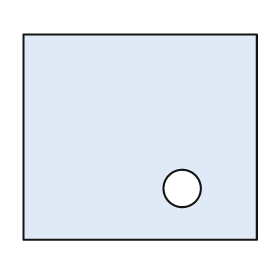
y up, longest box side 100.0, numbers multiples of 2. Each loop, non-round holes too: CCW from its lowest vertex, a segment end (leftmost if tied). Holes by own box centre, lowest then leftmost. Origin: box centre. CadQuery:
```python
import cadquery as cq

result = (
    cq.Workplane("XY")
    .moveTo(-50.0, -44.0)
    .lineTo(50.0, -44.0)
    .lineTo(50.0, 44.0)
    .lineTo(-50.0, 44.0)
    .close()
    .moveTo(18.0, -22.0)
    .circle(8.0)
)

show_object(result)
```